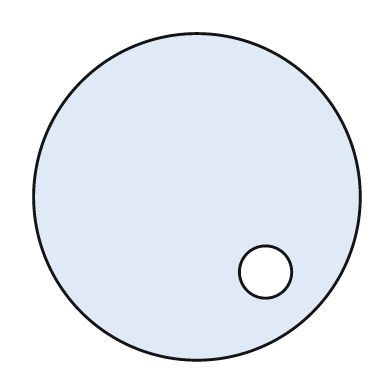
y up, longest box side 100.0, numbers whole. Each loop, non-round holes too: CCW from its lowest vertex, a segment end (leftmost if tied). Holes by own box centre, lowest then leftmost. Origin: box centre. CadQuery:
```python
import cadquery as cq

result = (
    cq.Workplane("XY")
    .moveTo(0.0, 0.0)
    .circle(50.0)
    .moveTo(21.0, -23.0)
    .circle(8.0)
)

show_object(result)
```